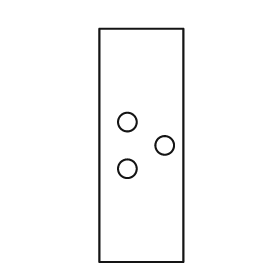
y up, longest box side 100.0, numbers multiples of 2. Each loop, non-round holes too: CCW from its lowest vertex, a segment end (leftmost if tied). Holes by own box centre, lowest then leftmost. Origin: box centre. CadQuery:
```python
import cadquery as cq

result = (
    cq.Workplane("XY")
    .moveTo(-18.0, -50.0)
    .lineTo(18.0, -50.0)
    .lineTo(18.0, 50.0)
    .lineTo(-18.0, 50.0)
    .close()
    .moveTo(-6.0, -10.0)
    .circle(4.0)
    .moveTo(10.0, 0.0)
    .circle(4.0)
    .moveTo(-6.0, 10.0)
    .circle(4.0)
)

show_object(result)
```